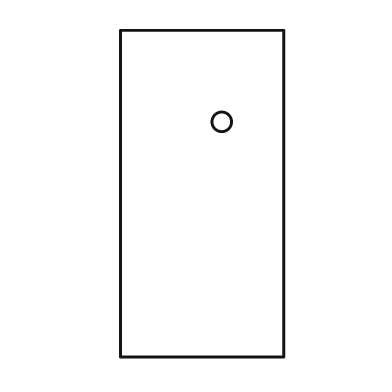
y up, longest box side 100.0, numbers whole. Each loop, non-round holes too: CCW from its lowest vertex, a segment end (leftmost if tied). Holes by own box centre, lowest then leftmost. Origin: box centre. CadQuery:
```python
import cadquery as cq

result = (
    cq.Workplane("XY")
    .moveTo(-25.0, -50.0)
    .lineTo(25.0, -50.0)
    .lineTo(25.0, 50.0)
    .lineTo(-25.0, 50.0)
    .close()
    .moveTo(6.0, 22.0)
    .circle(3.0)
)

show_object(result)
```